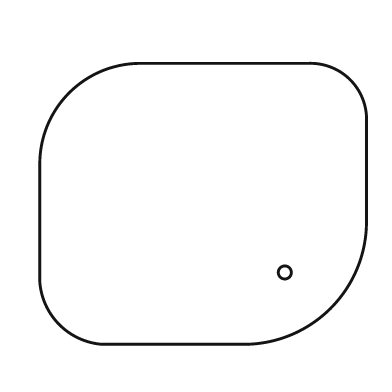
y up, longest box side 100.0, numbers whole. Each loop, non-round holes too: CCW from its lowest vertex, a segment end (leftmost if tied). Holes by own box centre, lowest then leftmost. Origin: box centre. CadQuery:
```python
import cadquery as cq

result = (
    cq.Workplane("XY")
    .moveTo(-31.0, -43.0)
    .lineTo(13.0, -43.0)
    .threePointArc((39.0, -32.0), (50.0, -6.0))
    .lineTo(50.0, 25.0)
    .threePointArc((45.0, 38.0), (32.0, 43.0))
    .lineTo(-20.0, 43.0)
    .threePointArc((-41.0, 34.0), (-50.0, 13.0))
    .lineTo(-50.0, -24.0)
    .threePointArc((-44.0, -37.0), (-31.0, -43.0))
    .close()
    .moveTo(25.0, -21.0)
    .circle(2.0)
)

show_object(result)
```